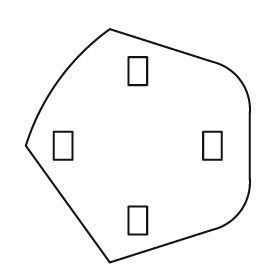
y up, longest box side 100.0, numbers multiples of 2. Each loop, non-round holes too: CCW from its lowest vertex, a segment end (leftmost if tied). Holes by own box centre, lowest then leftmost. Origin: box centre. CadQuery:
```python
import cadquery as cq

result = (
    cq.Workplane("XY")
    .moveTo(-12.0, -50.0)
    .lineTo(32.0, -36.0)
    .threePointArc((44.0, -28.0), (48.0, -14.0))
    .lineTo(48.0, 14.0)
    .threePointArc((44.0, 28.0), (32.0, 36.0))
    .lineTo(-12.0, 50.0)
    .threePointArc((-34.0, 28.0), (-48.0, 0.0))
    .close()
    .moveTo(-4.0, -38.0)
    .lineTo(4.0, -38.0)
    .lineTo(4.0, -26.0)
    .lineTo(-4.0, -26.0)
    .close()
    .moveTo(-36.0, -6.0)
    .lineTo(-28.0, -6.0)
    .lineTo(-28.0, 6.0)
    .lineTo(-36.0, 6.0)
    .close()
    .moveTo(28.0, -6.0)
    .lineTo(36.0, -6.0)
    .lineTo(36.0, 6.0)
    .lineTo(28.0, 6.0)
    .close()
    .moveTo(-4.0, 26.0)
    .lineTo(4.0, 26.0)
    .lineTo(4.0, 38.0)
    .lineTo(-4.0, 38.0)
    .close()
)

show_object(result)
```